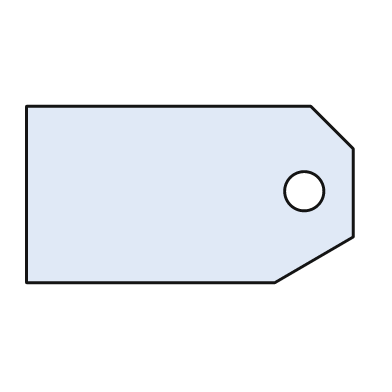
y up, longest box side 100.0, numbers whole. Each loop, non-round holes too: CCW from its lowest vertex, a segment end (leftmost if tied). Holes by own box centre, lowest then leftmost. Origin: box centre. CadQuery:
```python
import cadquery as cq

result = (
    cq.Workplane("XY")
    .moveTo(-50.0, -27.0)
    .lineTo(26.0, -27.0)
    .lineTo(50.0, -13.0)
    .lineTo(50.0, 14.0)
    .lineTo(37.0, 27.0)
    .lineTo(-50.0, 27.0)
    .close()
    .moveTo(35.0, 1.0)
    .circle(6.0)
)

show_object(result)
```